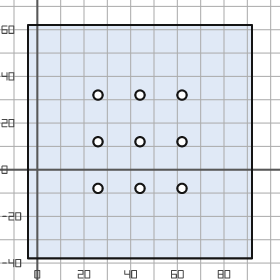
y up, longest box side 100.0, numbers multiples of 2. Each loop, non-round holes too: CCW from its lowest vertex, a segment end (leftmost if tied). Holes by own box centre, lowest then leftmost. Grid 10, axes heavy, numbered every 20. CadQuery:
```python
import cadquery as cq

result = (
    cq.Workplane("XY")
    .moveTo(-4.0, -38.0)
    .lineTo(92.0, -38.0)
    .lineTo(92.0, 62.0)
    .lineTo(-4.0, 62.0)
    .close()
    .moveTo(26.0, -8.0)
    .circle(2.0)
    .moveTo(44.0, -8.0)
    .circle(2.0)
    .moveTo(62.0, -8.0)
    .circle(2.0)
    .moveTo(26.0, 12.0)
    .circle(2.0)
    .moveTo(44.0, 12.0)
    .circle(2.0)
    .moveTo(62.0, 12.0)
    .circle(2.0)
    .moveTo(26.0, 32.0)
    .circle(2.0)
    .moveTo(44.0, 32.0)
    .circle(2.0)
    .moveTo(62.0, 32.0)
    .circle(2.0)
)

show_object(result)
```